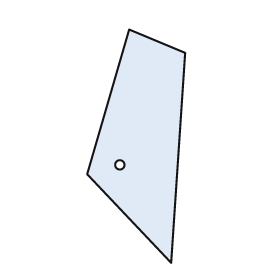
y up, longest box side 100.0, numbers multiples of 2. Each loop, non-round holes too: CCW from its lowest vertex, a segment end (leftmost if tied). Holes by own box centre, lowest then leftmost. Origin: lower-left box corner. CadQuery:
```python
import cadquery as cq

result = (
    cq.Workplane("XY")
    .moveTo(36.0, 0.0)
    .lineTo(42.0, 90.0)
    .lineTo(18.0, 100.0)
    .lineTo(0.0, 38.0)
    .close()
    .moveTo(14.0, 42.0)
    .circle(2.0)
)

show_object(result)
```